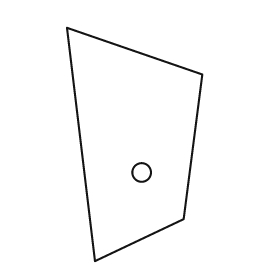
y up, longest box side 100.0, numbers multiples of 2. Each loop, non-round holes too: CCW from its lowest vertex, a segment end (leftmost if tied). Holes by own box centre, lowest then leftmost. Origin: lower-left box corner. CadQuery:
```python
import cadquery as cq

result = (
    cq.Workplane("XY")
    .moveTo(12.0, 0.0)
    .lineTo(50.0, 18.0)
    .lineTo(58.0, 80.0)
    .lineTo(0.0, 100.0)
    .close()
    .moveTo(32.0, 38.0)
    .circle(4.0)
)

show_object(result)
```